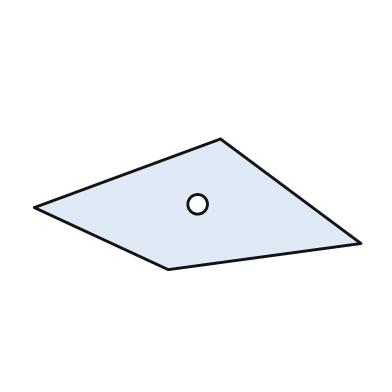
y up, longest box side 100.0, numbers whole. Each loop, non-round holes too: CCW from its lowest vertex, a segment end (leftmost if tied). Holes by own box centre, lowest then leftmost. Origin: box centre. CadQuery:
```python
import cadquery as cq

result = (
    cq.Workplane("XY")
    .moveTo(-9.0, -20.0)
    .lineTo(50.0, -12.0)
    .lineTo(7.0, 20.0)
    .lineTo(-50.0, -1.0)
    .close()
    .moveTo(0.0, 0.0)
    .circle(3.0)
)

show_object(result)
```